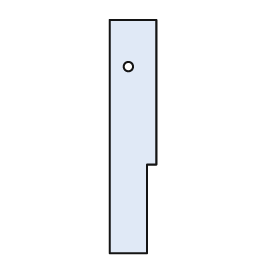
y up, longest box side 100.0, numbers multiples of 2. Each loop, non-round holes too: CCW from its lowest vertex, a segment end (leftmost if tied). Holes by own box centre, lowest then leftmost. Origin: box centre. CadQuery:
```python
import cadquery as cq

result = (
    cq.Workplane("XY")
    .moveTo(-10.0, -50.0)
    .lineTo(6.0, -50.0)
    .lineTo(6.0, -12.0)
    .lineTo(10.0, -12.0)
    .lineTo(10.0, 50.0)
    .lineTo(-10.0, 50.0)
    .close()
    .moveTo(-2.0, 30.0)
    .circle(2.0)
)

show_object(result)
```